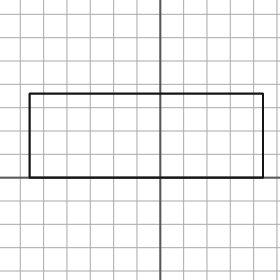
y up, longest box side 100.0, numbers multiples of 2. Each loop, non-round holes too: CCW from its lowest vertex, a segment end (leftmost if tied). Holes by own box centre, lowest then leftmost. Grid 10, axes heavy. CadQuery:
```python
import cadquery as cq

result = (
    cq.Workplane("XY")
    .moveTo(-56.0, 0.0)
    .lineTo(44.0, 0.0)
    .lineTo(44.0, 36.0)
    .lineTo(-56.0, 36.0)
    .close()
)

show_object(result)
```